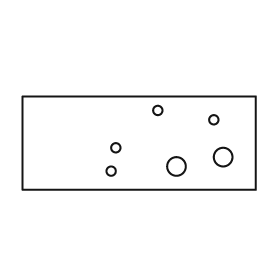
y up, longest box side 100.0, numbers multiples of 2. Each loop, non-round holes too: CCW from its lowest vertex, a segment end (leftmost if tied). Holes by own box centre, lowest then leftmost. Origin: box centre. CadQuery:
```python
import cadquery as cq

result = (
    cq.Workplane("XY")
    .moveTo(-50.0, -20.0)
    .lineTo(50.0, -20.0)
    .lineTo(50.0, 20.0)
    .lineTo(-50.0, 20.0)
    .close()
    .moveTo(-12.0, -12.0)
    .circle(2.0)
    .moveTo(16.0, -10.0)
    .circle(4.0)
    .moveTo(36.0, -6.0)
    .circle(4.0)
    .moveTo(-10.0, -2.0)
    .circle(2.0)
    .moveTo(32.0, 10.0)
    .circle(2.0)
    .moveTo(8.0, 14.0)
    .circle(2.0)
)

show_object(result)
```